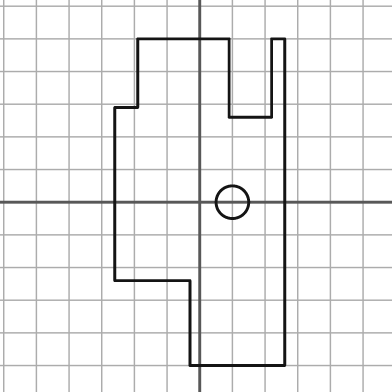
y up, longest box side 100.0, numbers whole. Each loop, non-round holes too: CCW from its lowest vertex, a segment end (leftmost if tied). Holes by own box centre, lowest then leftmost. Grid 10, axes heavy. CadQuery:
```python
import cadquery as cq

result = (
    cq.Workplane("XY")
    .moveTo(-3.0, -50.0)
    .lineTo(26.0, -50.0)
    .lineTo(26.0, 50.0)
    .lineTo(22.0, 50.0)
    .lineTo(22.0, 26.0)
    .lineTo(9.0, 26.0)
    .lineTo(9.0, 50.0)
    .lineTo(-19.0, 50.0)
    .lineTo(-19.0, 29.0)
    .lineTo(-26.0, 29.0)
    .lineTo(-26.0, -24.0)
    .lineTo(-3.0, -24.0)
    .close()
    .moveTo(10.0, 0.0)
    .circle(5.0)
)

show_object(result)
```